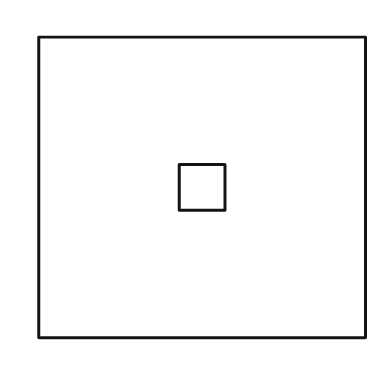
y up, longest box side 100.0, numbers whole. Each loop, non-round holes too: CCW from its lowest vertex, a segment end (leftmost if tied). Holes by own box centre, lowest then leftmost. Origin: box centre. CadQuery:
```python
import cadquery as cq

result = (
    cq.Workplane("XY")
    .moveTo(-50.0, -46.0)
    .lineTo(50.0, -46.0)
    .lineTo(50.0, 46.0)
    .lineTo(-50.0, 46.0)
    .close()
    .moveTo(-7.0, -7.0)
    .lineTo(7.0, -7.0)
    .lineTo(7.0, 7.0)
    .lineTo(-7.0, 7.0)
    .close()
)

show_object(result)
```